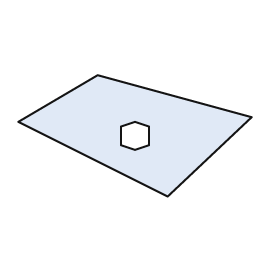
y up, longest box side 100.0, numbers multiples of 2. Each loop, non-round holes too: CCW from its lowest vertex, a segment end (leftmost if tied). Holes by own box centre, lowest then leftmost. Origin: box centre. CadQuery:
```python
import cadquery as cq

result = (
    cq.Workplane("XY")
    .moveTo(14.0, -26.0)
    .lineTo(50.0, 8.0)
    .lineTo(-16.0, 26.0)
    .lineTo(-50.0, 6.0)
    .close()
    .moveTo(0.0, -6.0)
    .lineTo(6.0, -4.0)
    .lineTo(6.0, 4.0)
    .lineTo(0.0, 6.0)
    .lineTo(-6.0, 4.0)
    .lineTo(-6.0, -4.0)
    .close()
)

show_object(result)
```